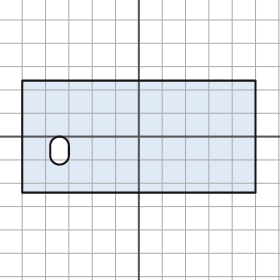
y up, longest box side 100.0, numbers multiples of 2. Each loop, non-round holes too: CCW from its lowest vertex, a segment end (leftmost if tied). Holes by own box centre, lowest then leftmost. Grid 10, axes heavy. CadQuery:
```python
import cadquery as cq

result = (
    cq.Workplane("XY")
    .moveTo(-50.0, -24.0)
    .lineTo(50.0, -24.0)
    .lineTo(50.0, 24.0)
    .lineTo(-50.0, 24.0)
    .close()
    .moveTo(-38.0, -8.0)
    .threePointArc((-34.0, -12.0), (-30.0, -8.0))
    .lineTo(-30.0, -4.0)
    .threePointArc((-34.0, 0.0), (-38.0, -4.0))
    .close()
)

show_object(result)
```